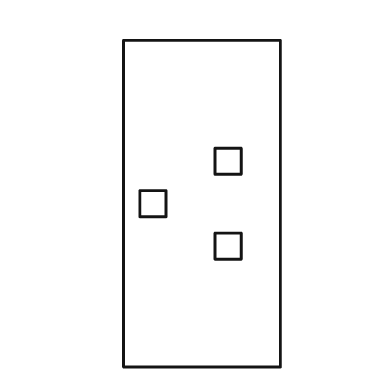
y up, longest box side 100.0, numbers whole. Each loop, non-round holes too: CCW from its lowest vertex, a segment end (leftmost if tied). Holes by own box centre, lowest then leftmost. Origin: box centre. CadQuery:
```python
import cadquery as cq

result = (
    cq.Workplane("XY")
    .moveTo(-24.0, -50.0)
    .lineTo(24.0, -50.0)
    .lineTo(24.0, 50.0)
    .lineTo(-24.0, 50.0)
    .close()
    .moveTo(4.0, -17.0)
    .lineTo(12.0, -17.0)
    .lineTo(12.0, -9.0)
    .lineTo(4.0, -9.0)
    .close()
    .moveTo(-19.0, -4.0)
    .lineTo(-11.0, -4.0)
    .lineTo(-11.0, 4.0)
    .lineTo(-19.0, 4.0)
    .close()
    .moveTo(4.0, 9.0)
    .lineTo(12.0, 9.0)
    .lineTo(12.0, 17.0)
    .lineTo(4.0, 17.0)
    .close()
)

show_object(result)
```